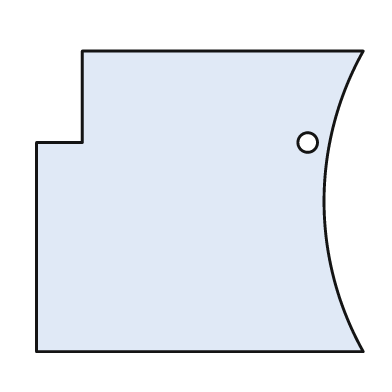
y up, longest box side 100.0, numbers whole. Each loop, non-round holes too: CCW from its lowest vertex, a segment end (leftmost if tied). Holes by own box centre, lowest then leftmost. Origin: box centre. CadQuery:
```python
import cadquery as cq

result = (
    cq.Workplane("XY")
    .moveTo(-50.0, -46.0)
    .lineTo(50.0, -46.0)
    .threePointArc((38.0, 0.0), (50.0, 46.0))
    .lineTo(-36.0, 46.0)
    .lineTo(-36.0, 18.0)
    .lineTo(-50.0, 18.0)
    .close()
    .moveTo(33.0, 18.0)
    .circle(3.0)
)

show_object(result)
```